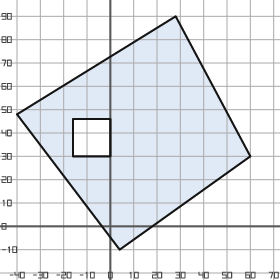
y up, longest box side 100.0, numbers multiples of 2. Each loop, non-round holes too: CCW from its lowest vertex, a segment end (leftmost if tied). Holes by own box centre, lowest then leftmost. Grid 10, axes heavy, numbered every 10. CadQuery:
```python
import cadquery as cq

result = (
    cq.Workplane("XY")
    .moveTo(4.0, -10.0)
    .lineTo(60.0, 30.0)
    .lineTo(28.0, 90.0)
    .lineTo(-40.0, 48.0)
    .close()
    .moveTo(-16.0, 30.0)
    .lineTo(0.0, 30.0)
    .lineTo(0.0, 46.0)
    .lineTo(-16.0, 46.0)
    .close()
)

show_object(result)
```